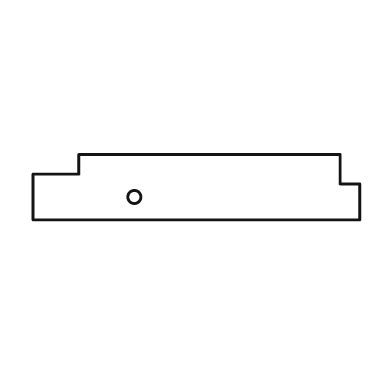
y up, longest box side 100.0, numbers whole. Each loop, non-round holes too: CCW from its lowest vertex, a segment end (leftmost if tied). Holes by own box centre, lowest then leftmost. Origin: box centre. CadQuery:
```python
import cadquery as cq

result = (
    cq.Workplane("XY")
    .moveTo(-50.0, -10.0)
    .lineTo(50.0, -10.0)
    .lineTo(50.0, 1.0)
    .lineTo(44.0, 1.0)
    .lineTo(44.0, 10.0)
    .lineTo(-36.0, 10.0)
    .lineTo(-36.0, 4.0)
    .lineTo(-50.0, 4.0)
    .close()
    .moveTo(-19.0, -3.0)
    .circle(2.0)
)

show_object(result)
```